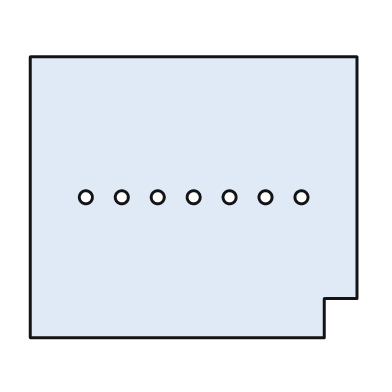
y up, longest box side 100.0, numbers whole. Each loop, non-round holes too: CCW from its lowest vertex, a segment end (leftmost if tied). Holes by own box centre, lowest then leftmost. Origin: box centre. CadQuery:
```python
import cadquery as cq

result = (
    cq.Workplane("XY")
    .moveTo(-50.0, -43.0)
    .lineTo(40.0, -43.0)
    .lineTo(40.0, -31.0)
    .lineTo(50.0, -31.0)
    .lineTo(50.0, 43.0)
    .lineTo(-50.0, 43.0)
    .close()
    .moveTo(-33.0, 0.0)
    .circle(2.0)
    .moveTo(-22.0, 0.0)
    .circle(2.0)
    .moveTo(-11.0, 0.0)
    .circle(2.0)
    .moveTo(0.0, 0.0)
    .circle(2.0)
    .moveTo(11.0, 0.0)
    .circle(2.0)
    .moveTo(22.0, 0.0)
    .circle(2.0)
    .moveTo(33.0, 0.0)
    .circle(2.0)
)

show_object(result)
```